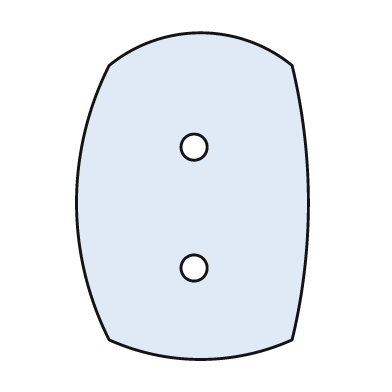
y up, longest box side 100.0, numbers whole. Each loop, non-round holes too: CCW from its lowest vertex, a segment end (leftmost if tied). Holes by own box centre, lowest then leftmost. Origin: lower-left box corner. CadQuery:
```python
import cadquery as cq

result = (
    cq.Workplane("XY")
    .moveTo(10.0, 6.0)
    .threePointArc((38.0, 0.0), (66.0, 6.0))
    .threePointArc((71.0, 48.0), (66.0, 90.0))
    .threePointArc((38.0, 100.0), (10.0, 90.0))
    .threePointArc((0.0, 48.0), (10.0, 6.0))
    .close()
    .moveTo(36.0, 28.0)
    .circle(4.0)
    .moveTo(36.0, 65.0)
    .circle(4.0)
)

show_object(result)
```